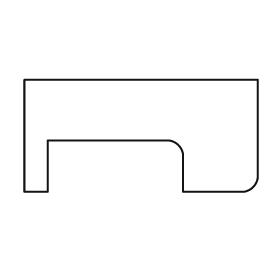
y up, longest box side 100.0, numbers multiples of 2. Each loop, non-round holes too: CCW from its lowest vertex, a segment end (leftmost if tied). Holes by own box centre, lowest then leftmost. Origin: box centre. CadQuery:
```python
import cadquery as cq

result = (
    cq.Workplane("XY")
    .moveTo(-50.0, -24.0)
    .lineTo(-40.0, -24.0)
    .lineTo(-40.0, -2.0)
    .lineTo(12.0, -2.0)
    .threePointArc((16.0, -4.0), (18.0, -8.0))
    .lineTo(18.0, -24.0)
    .lineTo(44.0, -24.0)
    .threePointArc((48.0, -22.0), (50.0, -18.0))
    .lineTo(50.0, 24.0)
    .lineTo(-50.0, 24.0)
    .close()
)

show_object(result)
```